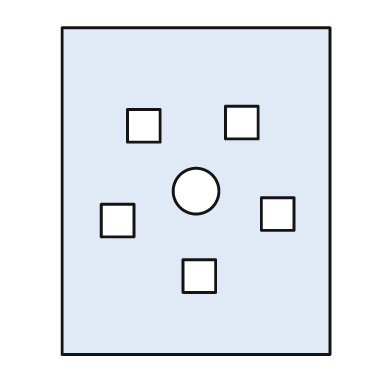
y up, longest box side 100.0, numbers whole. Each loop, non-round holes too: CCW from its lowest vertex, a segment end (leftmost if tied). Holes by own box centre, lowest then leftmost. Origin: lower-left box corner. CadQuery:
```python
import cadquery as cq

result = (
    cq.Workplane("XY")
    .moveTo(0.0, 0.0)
    .lineTo(82.0, 0.0)
    .lineTo(82.0, 100.0)
    .lineTo(0.0, 100.0)
    .close()
    .moveTo(37.0, 19.0)
    .lineTo(47.0, 19.0)
    .lineTo(47.0, 29.0)
    .lineTo(37.0, 29.0)
    .close()
    .moveTo(12.0, 36.0)
    .lineTo(22.0, 36.0)
    .lineTo(22.0, 46.0)
    .lineTo(12.0, 46.0)
    .close()
    .moveTo(61.0, 38.0)
    .lineTo(71.0, 38.0)
    .lineTo(71.0, 48.0)
    .lineTo(61.0, 48.0)
    .close()
    .moveTo(41.0, 50.0)
    .circle(7.0)
    .moveTo(20.0, 65.0)
    .lineTo(30.0, 65.0)
    .lineTo(30.0, 75.0)
    .lineTo(20.0, 75.0)
    .close()
    .moveTo(50.0, 66.0)
    .lineTo(60.0, 66.0)
    .lineTo(60.0, 76.0)
    .lineTo(50.0, 76.0)
    .close()
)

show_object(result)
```